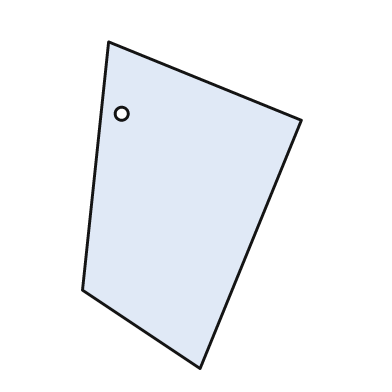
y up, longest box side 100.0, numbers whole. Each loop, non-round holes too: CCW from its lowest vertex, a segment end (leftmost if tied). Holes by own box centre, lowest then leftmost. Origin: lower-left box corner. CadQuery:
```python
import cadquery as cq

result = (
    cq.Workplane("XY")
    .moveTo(36.0, 0.0)
    .lineTo(67.0, 76.0)
    .lineTo(8.0, 100.0)
    .lineTo(0.0, 24.0)
    .close()
    .moveTo(12.0, 78.0)
    .circle(2.0)
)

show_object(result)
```